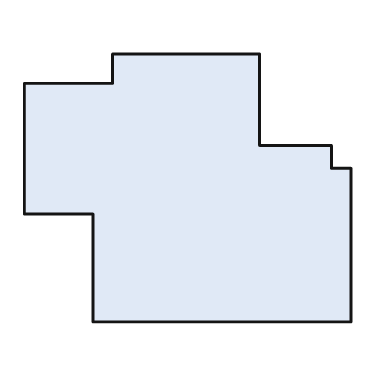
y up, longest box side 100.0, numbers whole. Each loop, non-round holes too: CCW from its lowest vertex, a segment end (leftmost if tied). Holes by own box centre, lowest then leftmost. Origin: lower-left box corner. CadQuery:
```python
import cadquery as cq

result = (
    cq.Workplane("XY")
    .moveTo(21.0, 0.0)
    .lineTo(100.0, 0.0)
    .lineTo(100.0, 47.0)
    .lineTo(94.0, 47.0)
    .lineTo(94.0, 54.0)
    .lineTo(72.0, 54.0)
    .lineTo(72.0, 82.0)
    .lineTo(27.0, 82.0)
    .lineTo(27.0, 73.0)
    .lineTo(0.0, 73.0)
    .lineTo(0.0, 33.0)
    .lineTo(21.0, 33.0)
    .close()
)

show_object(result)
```